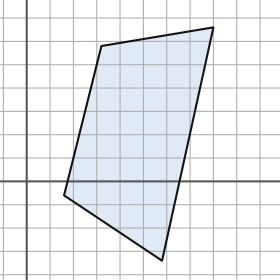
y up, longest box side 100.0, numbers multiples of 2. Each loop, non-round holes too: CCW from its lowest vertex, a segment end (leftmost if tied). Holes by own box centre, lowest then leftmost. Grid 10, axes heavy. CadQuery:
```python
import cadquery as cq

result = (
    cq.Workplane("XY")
    .moveTo(58.0, -34.0)
    .lineTo(80.0, 66.0)
    .lineTo(32.0, 58.0)
    .lineTo(16.0, -6.0)
    .close()
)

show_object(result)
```